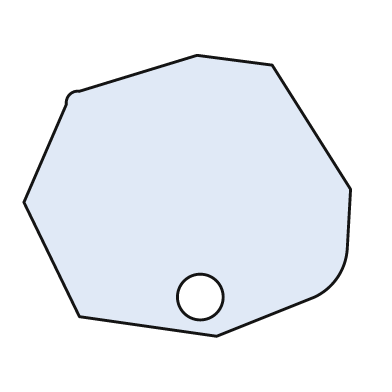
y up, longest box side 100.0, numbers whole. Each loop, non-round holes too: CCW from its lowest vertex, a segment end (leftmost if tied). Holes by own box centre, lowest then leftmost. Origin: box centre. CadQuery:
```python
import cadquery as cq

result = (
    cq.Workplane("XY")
    .moveTo(9.0, -43.0)
    .lineTo(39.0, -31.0)
    .threePointArc((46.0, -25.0), (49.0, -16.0))
    .lineTo(50.0, 2.0)
    .lineTo(26.0, 40.0)
    .lineTo(3.0, 43.0)
    .lineTo(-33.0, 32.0)
    .threePointArc((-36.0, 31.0), (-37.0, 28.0))
    .lineTo(-50.0, -2.0)
    .lineTo(-33.0, -37.0)
    .close()
    .moveTo(4.0, -31.0)
    .circle(7.0)
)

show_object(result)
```